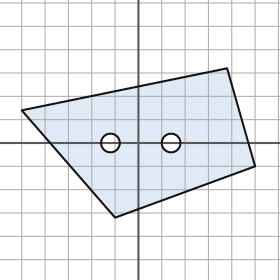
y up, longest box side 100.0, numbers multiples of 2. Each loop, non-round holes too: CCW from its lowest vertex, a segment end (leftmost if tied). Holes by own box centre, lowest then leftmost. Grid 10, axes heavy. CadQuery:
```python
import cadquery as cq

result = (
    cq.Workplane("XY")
    .moveTo(-10.0, -32.0)
    .lineTo(50.0, -10.0)
    .lineTo(38.0, 32.0)
    .lineTo(-50.0, 14.0)
    .close()
    .moveTo(-12.0, 0.0)
    .circle(4.0)
    .moveTo(14.0, 0.0)
    .circle(4.0)
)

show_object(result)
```